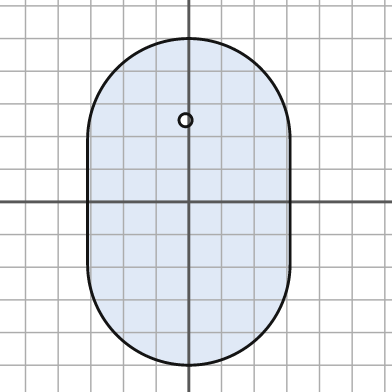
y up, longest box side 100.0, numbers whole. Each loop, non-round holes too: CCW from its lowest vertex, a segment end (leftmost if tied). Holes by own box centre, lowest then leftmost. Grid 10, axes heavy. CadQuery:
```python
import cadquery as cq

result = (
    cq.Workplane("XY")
    .moveTo(-31.0, -19.0)
    .threePointArc((0.0, -50.0), (31.0, -19.0))
    .lineTo(31.0, 19.0)
    .threePointArc((0.0, 50.0), (-31.0, 19.0))
    .close()
    .moveTo(-1.0, 25.0)
    .circle(2.0)
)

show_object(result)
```